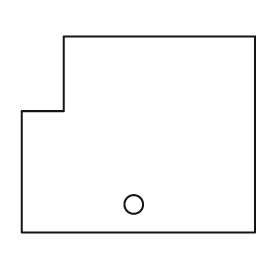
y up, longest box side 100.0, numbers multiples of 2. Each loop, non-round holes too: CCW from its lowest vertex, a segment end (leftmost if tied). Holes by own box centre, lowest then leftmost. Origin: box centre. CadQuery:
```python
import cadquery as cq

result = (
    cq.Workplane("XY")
    .moveTo(-50.0, -42.0)
    .lineTo(50.0, -42.0)
    .lineTo(50.0, 42.0)
    .lineTo(-32.0, 42.0)
    .lineTo(-32.0, 10.0)
    .lineTo(-50.0, 10.0)
    .close()
    .moveTo(-2.0, -30.0)
    .circle(4.0)
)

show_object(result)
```